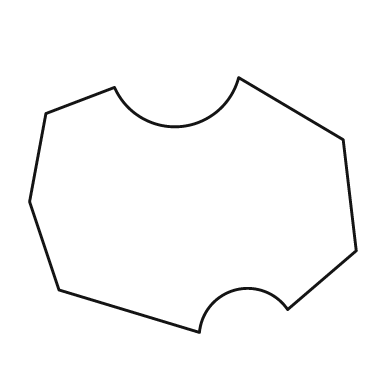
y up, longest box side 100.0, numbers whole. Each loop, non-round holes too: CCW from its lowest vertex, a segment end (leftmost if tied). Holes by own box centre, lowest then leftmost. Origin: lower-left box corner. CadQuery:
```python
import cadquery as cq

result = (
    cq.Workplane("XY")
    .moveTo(52.0, 0.0)
    .threePointArc((63.0, 13.0), (79.0, 7.0))
    .lineTo(100.0, 25.0)
    .lineTo(96.0, 59.0)
    .lineTo(64.0, 78.0)
    .threePointArc((46.0, 63.0), (26.0, 75.0))
    .lineTo(5.0, 67.0)
    .lineTo(0.0, 40.0)
    .lineTo(9.0, 13.0)
    .close()
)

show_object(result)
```